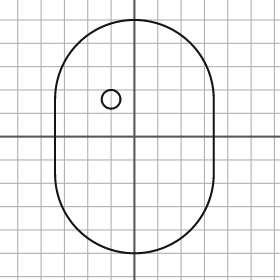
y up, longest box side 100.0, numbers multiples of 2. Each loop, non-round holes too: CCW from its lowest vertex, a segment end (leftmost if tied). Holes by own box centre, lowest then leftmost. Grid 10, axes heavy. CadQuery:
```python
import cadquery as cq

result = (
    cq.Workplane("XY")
    .moveTo(-34.0, -16.0)
    .threePointArc((0.0, -50.0), (34.0, -16.0))
    .lineTo(34.0, 16.0)
    .threePointArc((0.0, 50.0), (-34.0, 16.0))
    .close()
    .moveTo(-10.0, 16.0)
    .circle(4.0)
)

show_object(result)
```